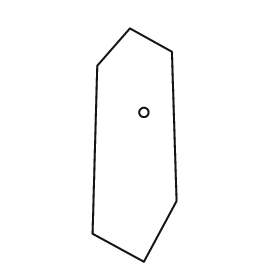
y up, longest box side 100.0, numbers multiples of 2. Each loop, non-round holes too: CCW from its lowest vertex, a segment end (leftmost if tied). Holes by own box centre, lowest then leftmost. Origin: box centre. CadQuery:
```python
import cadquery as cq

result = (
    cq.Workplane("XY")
    .moveTo(4.0, -50.0)
    .lineTo(18.0, -24.0)
    .lineTo(16.0, 40.0)
    .lineTo(-2.0, 50.0)
    .lineTo(-16.0, 34.0)
    .lineTo(-18.0, -38.0)
    .close()
    .moveTo(4.0, 14.0)
    .circle(2.0)
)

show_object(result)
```